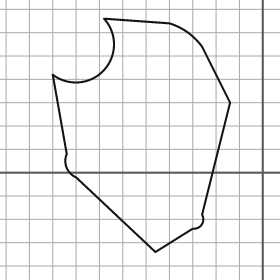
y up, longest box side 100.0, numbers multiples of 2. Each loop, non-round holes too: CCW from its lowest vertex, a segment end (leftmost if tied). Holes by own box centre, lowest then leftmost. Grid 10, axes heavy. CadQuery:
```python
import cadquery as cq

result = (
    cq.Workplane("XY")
    .moveTo(-46.0, -34.0)
    .lineTo(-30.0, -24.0)
    .threePointArc((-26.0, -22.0), (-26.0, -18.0))
    .lineTo(-14.0, 30.0)
    .lineTo(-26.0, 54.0)
    .threePointArc((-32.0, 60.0), (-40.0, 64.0))
    .lineTo(-68.0, 66.0)
    .threePointArc((-68.0, 44.0), (-90.0, 42.0))
    .lineTo(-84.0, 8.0)
    .threePointArc((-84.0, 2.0), (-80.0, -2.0))
    .close()
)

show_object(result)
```